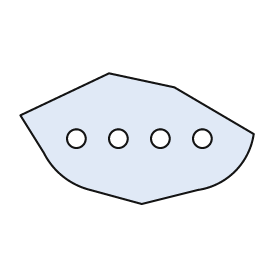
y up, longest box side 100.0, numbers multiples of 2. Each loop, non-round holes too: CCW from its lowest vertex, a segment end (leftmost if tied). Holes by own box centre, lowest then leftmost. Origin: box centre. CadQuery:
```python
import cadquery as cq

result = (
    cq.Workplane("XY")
    .moveTo(2.0, -28.0)
    .lineTo(26.0, -22.0)
    .threePointArc((42.0, -14.0), (50.0, 2.0))
    .lineTo(16.0, 22.0)
    .lineTo(-12.0, 28.0)
    .lineTo(-50.0, 10.0)
    .lineTo(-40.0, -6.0)
    .threePointArc((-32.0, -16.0), (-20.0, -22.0))
    .close()
    .moveTo(-26.0, 0.0)
    .circle(4.0)
    .moveTo(-8.0, 0.0)
    .circle(4.0)
    .moveTo(10.0, 0.0)
    .circle(4.0)
    .moveTo(28.0, 0.0)
    .circle(4.0)
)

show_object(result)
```